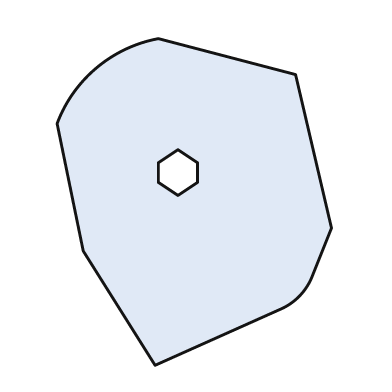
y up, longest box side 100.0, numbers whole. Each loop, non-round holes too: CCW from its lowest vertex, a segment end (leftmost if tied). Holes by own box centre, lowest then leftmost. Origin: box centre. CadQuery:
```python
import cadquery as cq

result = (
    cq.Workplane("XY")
    .moveTo(-12.0, -50.0)
    .lineTo(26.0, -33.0)
    .threePointArc((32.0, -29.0), (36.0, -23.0))
    .lineTo(42.0, -8.0)
    .lineTo(31.0, 39.0)
    .lineTo(-11.0, 50.0)
    .threePointArc((-30.0, 41.0), (-42.0, 24.0))
    .lineTo(-34.0, -15.0)
    .close()
    .moveTo(-5.0, 2.0)
    .lineTo(1.0, 6.0)
    .lineTo(1.0, 12.0)
    .lineTo(-5.0, 16.0)
    .lineTo(-11.0, 12.0)
    .lineTo(-11.0, 6.0)
    .close()
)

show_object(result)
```